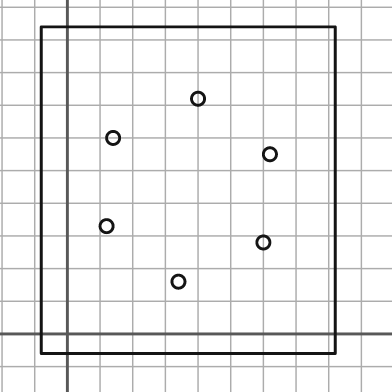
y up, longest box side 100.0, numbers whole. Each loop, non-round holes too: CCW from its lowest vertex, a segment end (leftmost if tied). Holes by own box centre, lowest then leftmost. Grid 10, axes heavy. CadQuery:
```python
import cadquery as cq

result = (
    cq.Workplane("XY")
    .moveTo(-8.0, -6.0)
    .lineTo(82.0, -6.0)
    .lineTo(82.0, 94.0)
    .lineTo(-8.0, 94.0)
    .close()
    .moveTo(34.0, 16.0)
    .circle(2.0)
    .moveTo(60.0, 28.0)
    .circle(2.0)
    .moveTo(12.0, 33.0)
    .circle(2.0)
    .moveTo(62.0, 55.0)
    .circle(2.0)
    .moveTo(14.0, 60.0)
    .circle(2.0)
    .moveTo(40.0, 72.0)
    .circle(2.0)
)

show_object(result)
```